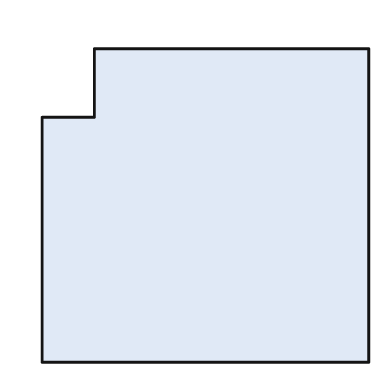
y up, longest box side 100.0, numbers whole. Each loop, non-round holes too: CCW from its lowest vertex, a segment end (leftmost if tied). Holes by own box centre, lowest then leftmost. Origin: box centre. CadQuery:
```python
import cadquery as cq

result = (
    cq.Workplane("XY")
    .moveTo(-50.0, -48.0)
    .lineTo(50.0, -48.0)
    .lineTo(50.0, 48.0)
    .lineTo(-34.0, 48.0)
    .lineTo(-34.0, 27.0)
    .lineTo(-50.0, 27.0)
    .close()
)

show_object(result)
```